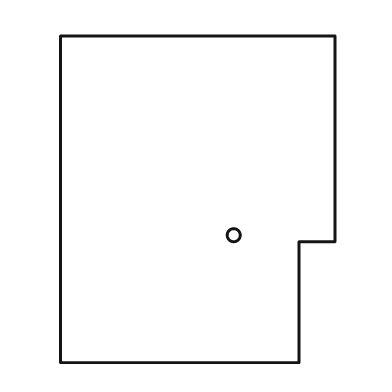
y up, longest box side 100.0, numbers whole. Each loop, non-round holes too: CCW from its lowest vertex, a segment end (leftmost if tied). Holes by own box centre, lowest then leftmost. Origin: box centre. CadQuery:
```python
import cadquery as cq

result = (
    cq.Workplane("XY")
    .moveTo(-42.0, -50.0)
    .lineTo(31.0, -50.0)
    .lineTo(31.0, -13.0)
    .lineTo(42.0, -13.0)
    .lineTo(42.0, 50.0)
    .lineTo(-42.0, 50.0)
    .close()
    .moveTo(11.0, -11.0)
    .circle(2.0)
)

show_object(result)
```